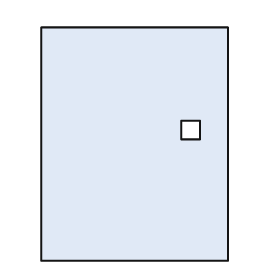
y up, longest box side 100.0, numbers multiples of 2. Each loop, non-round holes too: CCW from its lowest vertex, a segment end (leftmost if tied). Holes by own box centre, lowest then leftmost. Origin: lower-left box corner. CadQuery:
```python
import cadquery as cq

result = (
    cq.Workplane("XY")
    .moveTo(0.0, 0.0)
    .lineTo(80.0, 0.0)
    .lineTo(80.0, 100.0)
    .lineTo(0.0, 100.0)
    .close()
    .moveTo(60.0, 52.0)
    .lineTo(68.0, 52.0)
    .lineTo(68.0, 60.0)
    .lineTo(60.0, 60.0)
    .close()
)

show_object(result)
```